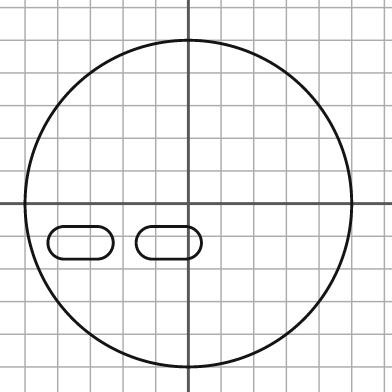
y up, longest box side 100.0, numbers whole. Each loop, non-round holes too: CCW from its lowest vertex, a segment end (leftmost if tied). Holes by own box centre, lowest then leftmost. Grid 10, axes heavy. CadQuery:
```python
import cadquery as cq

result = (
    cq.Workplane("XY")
    .moveTo(0.0, 0.0)
    .circle(50.0)
    .moveTo(-38.0, -17.0)
    .lineTo(-28.0, -17.0)
    .threePointArc((-23.0, -12.0), (-28.0, -7.0))
    .lineTo(-38.0, -7.0)
    .threePointArc((-43.0, -12.0), (-38.0, -17.0))
    .close()
    .moveTo(-11.0, -17.0)
    .lineTo(-1.0, -17.0)
    .threePointArc((4.0, -12.0), (-1.0, -7.0))
    .lineTo(-11.0, -7.0)
    .threePointArc((-16.0, -12.0), (-11.0, -17.0))
    .close()
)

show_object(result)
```